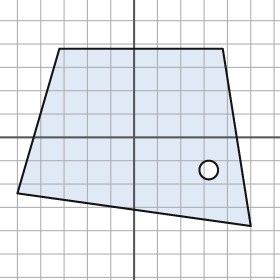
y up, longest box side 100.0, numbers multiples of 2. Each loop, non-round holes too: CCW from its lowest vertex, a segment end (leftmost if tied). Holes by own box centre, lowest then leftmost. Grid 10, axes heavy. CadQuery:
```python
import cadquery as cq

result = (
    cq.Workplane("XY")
    .moveTo(50.0, -38.0)
    .lineTo(38.0, 38.0)
    .lineTo(-32.0, 38.0)
    .lineTo(-50.0, -24.0)
    .close()
    .moveTo(32.0, -14.0)
    .circle(4.0)
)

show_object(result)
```